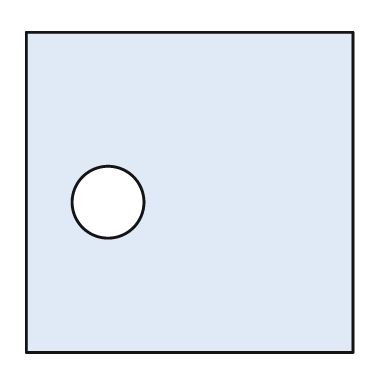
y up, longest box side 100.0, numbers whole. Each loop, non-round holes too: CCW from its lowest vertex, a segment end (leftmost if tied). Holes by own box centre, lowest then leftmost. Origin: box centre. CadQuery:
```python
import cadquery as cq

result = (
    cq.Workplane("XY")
    .moveTo(-50.0, -49.0)
    .lineTo(50.0, -49.0)
    .lineTo(50.0, 49.0)
    .lineTo(-50.0, 49.0)
    .close()
    .moveTo(-25.0, -3.0)
    .circle(11.0)
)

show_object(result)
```